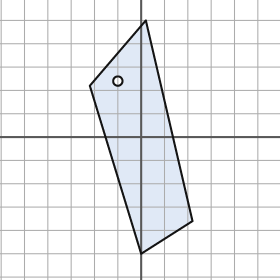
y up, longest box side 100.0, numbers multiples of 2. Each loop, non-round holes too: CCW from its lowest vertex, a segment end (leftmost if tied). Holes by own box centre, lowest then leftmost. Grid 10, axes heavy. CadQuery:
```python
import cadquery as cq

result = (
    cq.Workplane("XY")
    .moveTo(0.0, -50.0)
    .lineTo(22.0, -36.0)
    .lineTo(2.0, 50.0)
    .lineTo(-22.0, 22.0)
    .close()
    .moveTo(-10.0, 24.0)
    .circle(2.0)
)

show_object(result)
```